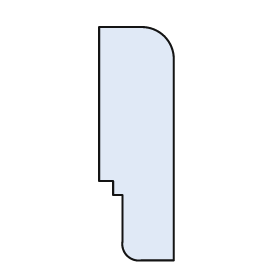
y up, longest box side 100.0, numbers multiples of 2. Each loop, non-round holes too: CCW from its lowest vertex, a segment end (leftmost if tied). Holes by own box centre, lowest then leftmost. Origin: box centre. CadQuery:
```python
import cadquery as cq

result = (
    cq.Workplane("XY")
    .moveTo(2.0, -50.0)
    .lineTo(16.0, -50.0)
    .lineTo(16.0, 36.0)
    .threePointArc((12.0, 46.0), (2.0, 50.0))
    .lineTo(-16.0, 50.0)
    .lineTo(-16.0, -16.0)
    .lineTo(-10.0, -16.0)
    .lineTo(-10.0, -22.0)
    .lineTo(-6.0, -22.0)
    .lineTo(-6.0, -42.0)
    .threePointArc((-4.0, -48.0), (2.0, -50.0))
    .close()
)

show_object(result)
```